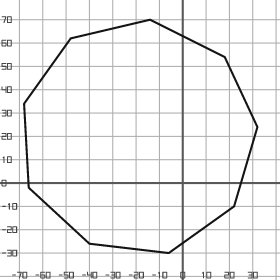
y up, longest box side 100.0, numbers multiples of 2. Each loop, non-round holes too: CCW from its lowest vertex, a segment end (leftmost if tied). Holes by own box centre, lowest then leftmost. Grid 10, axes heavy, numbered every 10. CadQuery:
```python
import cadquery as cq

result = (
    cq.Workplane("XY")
    .moveTo(-6.0, -30.0)
    .lineTo(22.0, -10.0)
    .lineTo(32.0, 24.0)
    .lineTo(18.0, 54.0)
    .lineTo(-14.0, 70.0)
    .lineTo(-48.0, 62.0)
    .lineTo(-68.0, 34.0)
    .lineTo(-66.0, -2.0)
    .lineTo(-40.0, -26.0)
    .close()
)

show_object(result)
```